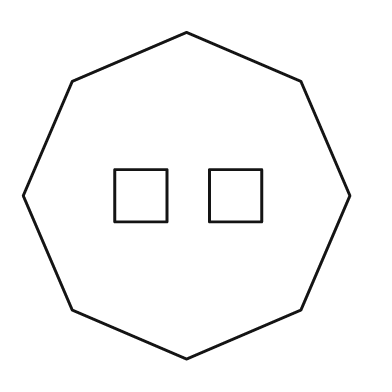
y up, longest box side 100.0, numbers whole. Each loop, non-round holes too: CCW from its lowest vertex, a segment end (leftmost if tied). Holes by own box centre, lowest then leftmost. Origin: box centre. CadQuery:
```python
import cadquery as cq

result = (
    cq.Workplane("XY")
    .moveTo(0.0, -50.0)
    .lineTo(35.0, -35.0)
    .lineTo(50.0, 0.0)
    .lineTo(35.0, 35.0)
    .lineTo(0.0, 50.0)
    .lineTo(-35.0, 35.0)
    .lineTo(-50.0, 0.0)
    .lineTo(-35.0, -35.0)
    .close()
    .moveTo(-22.0, -8.0)
    .lineTo(-6.0, -8.0)
    .lineTo(-6.0, 8.0)
    .lineTo(-22.0, 8.0)
    .close()
    .moveTo(7.0, -8.0)
    .lineTo(23.0, -8.0)
    .lineTo(23.0, 8.0)
    .lineTo(7.0, 8.0)
    .close()
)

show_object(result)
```